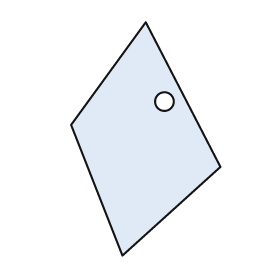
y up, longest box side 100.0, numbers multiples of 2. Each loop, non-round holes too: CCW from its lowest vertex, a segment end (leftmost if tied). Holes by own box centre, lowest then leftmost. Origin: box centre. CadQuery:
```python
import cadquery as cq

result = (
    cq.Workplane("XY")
    .moveTo(-10.0, -50.0)
    .lineTo(32.0, -12.0)
    .lineTo(0.0, 50.0)
    .lineTo(-32.0, 6.0)
    .close()
    .moveTo(8.0, 16.0)
    .circle(4.0)
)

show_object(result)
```